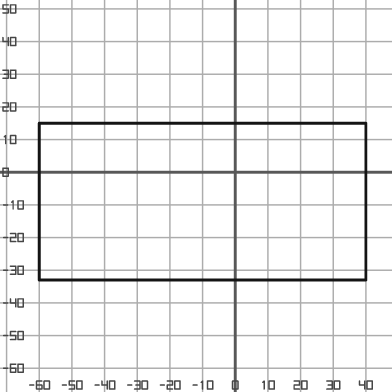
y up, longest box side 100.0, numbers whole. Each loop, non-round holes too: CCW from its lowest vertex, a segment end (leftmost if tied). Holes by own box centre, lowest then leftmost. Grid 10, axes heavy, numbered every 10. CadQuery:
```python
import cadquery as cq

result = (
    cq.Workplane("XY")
    .moveTo(-60.0, -33.0)
    .lineTo(40.0, -33.0)
    .lineTo(40.0, 15.0)
    .lineTo(-60.0, 15.0)
    .close()
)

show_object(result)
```